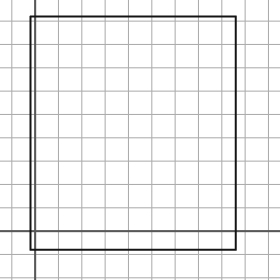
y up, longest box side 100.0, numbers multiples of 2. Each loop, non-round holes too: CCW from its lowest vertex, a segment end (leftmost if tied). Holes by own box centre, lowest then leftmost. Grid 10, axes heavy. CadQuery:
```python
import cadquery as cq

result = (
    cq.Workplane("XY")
    .moveTo(-2.0, -8.0)
    .lineTo(86.0, -8.0)
    .lineTo(86.0, 92.0)
    .lineTo(-2.0, 92.0)
    .close()
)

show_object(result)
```